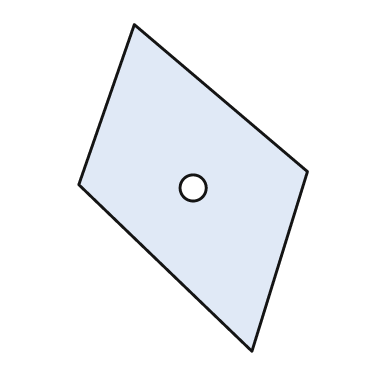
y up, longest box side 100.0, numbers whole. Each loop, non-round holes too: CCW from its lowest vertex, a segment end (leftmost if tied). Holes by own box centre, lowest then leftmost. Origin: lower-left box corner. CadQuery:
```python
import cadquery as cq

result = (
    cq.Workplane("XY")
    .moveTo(53.0, 0.0)
    .lineTo(70.0, 55.0)
    .lineTo(17.0, 100.0)
    .lineTo(0.0, 51.0)
    .close()
    .moveTo(35.0, 50.0)
    .circle(4.0)
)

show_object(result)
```